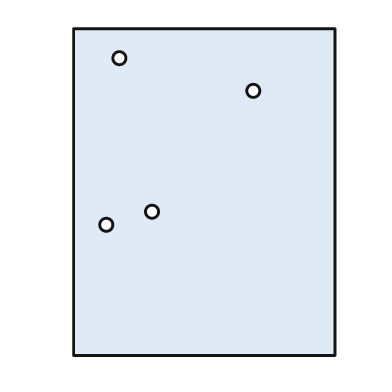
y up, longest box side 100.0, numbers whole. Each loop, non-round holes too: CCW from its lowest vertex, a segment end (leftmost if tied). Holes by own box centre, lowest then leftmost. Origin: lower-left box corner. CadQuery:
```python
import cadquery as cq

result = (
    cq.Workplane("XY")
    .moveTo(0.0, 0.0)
    .lineTo(80.0, 0.0)
    .lineTo(80.0, 100.0)
    .lineTo(0.0, 100.0)
    .close()
    .moveTo(10.0, 40.0)
    .circle(2.0)
    .moveTo(24.0, 44.0)
    .circle(2.0)
    .moveTo(55.0, 81.0)
    .circle(2.0)
    .moveTo(14.0, 91.0)
    .circle(2.0)
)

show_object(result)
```